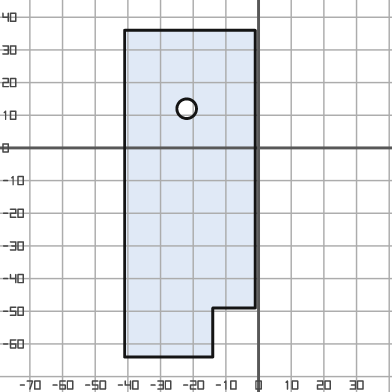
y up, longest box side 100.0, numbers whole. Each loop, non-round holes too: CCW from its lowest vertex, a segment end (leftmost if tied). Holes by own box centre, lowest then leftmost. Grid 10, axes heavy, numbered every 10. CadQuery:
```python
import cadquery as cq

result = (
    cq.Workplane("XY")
    .moveTo(-41.0, -64.0)
    .lineTo(-14.0, -64.0)
    .lineTo(-14.0, -49.0)
    .lineTo(-1.0, -49.0)
    .lineTo(-1.0, 36.0)
    .lineTo(-41.0, 36.0)
    .close()
    .moveTo(-22.0, 12.0)
    .circle(3.0)
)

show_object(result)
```